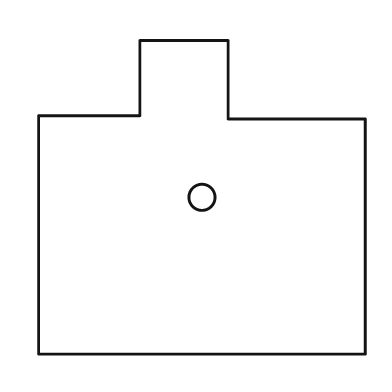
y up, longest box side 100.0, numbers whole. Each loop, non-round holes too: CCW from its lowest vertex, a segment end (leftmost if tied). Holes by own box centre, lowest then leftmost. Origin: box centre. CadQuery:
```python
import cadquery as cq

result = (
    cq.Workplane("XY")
    .moveTo(-50.0, -48.0)
    .lineTo(50.0, -48.0)
    .lineTo(50.0, 24.0)
    .lineTo(8.0, 24.0)
    .lineTo(8.0, 48.0)
    .lineTo(-19.0, 48.0)
    .lineTo(-19.0, 25.0)
    .lineTo(-50.0, 25.0)
    .close()
    .moveTo(0.0, 0.0)
    .circle(4.0)
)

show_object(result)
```